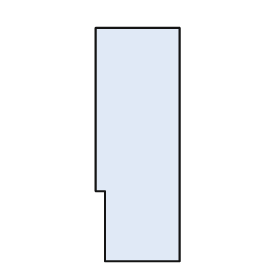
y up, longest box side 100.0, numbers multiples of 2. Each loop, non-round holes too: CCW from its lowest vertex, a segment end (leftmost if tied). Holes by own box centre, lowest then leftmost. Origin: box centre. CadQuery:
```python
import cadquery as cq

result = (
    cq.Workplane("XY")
    .moveTo(-14.0, -50.0)
    .lineTo(18.0, -50.0)
    .lineTo(18.0, 50.0)
    .lineTo(-18.0, 50.0)
    .lineTo(-18.0, -20.0)
    .lineTo(-14.0, -20.0)
    .close()
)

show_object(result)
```